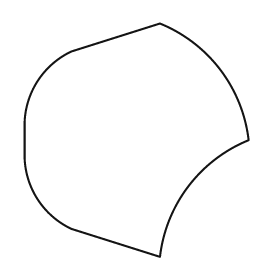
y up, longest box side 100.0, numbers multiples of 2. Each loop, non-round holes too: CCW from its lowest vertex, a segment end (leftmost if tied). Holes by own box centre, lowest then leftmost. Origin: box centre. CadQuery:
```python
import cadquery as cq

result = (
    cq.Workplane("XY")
    .moveTo(10.0, -50.0)
    .threePointArc((22.0, -20.0), (48.0, 0.0))
    .threePointArc((36.0, 30.0), (10.0, 50.0))
    .lineTo(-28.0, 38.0)
    .threePointArc((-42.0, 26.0), (-48.0, 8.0))
    .lineTo(-48.0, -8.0)
    .threePointArc((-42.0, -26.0), (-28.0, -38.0))
    .close()
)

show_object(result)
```